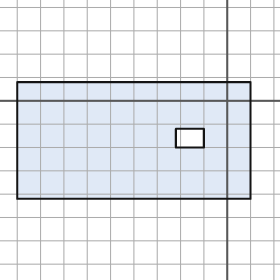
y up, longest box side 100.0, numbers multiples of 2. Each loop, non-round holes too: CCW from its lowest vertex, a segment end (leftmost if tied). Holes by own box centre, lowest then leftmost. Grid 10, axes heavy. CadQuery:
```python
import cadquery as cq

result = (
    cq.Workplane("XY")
    .moveTo(-90.0, -42.0)
    .lineTo(10.0, -42.0)
    .lineTo(10.0, 8.0)
    .lineTo(-90.0, 8.0)
    .close()
    .moveTo(-22.0, -20.0)
    .lineTo(-10.0, -20.0)
    .lineTo(-10.0, -12.0)
    .lineTo(-22.0, -12.0)
    .close()
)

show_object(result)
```